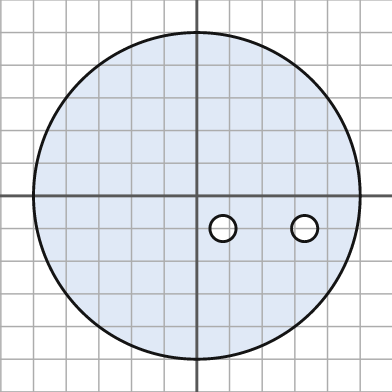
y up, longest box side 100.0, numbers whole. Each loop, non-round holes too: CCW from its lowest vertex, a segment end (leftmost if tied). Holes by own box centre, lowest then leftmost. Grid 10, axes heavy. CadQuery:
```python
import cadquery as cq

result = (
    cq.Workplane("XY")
    .moveTo(0.0, 0.0)
    .circle(50.0)
    .moveTo(8.0, -10.0)
    .circle(4.0)
    .moveTo(33.0, -10.0)
    .circle(4.0)
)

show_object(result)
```